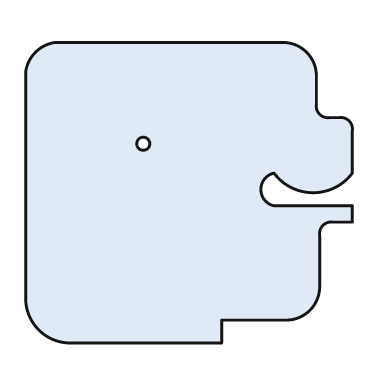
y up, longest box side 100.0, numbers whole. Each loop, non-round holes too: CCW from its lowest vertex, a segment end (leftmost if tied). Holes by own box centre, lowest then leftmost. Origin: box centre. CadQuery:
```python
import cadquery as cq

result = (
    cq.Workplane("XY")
    .moveTo(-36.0, -46.0)
    .lineTo(10.0, -46.0)
    .lineTo(10.0, -39.0)
    .lineTo(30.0, -39.0)
    .threePointArc((37.0, -36.0), (40.0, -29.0))
    .lineTo(40.0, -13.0)
    .threePointArc((41.0, -10.0), (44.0, -9.0))
    .lineTo(50.0, -9.0)
    .lineTo(50.0, -4.0)
    .lineTo(26.0, -4.0)
    .threePointArc((22.0, 1.0), (26.0, 6.0))
    .threePointArc((38.0, 0.0), (50.0, 6.0))
    .lineTo(50.0, 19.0)
    .threePointArc((49.0, 22.0), (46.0, 23.0))
    .lineTo(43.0, 23.0)
    .threePointArc((40.0, 24.0), (39.0, 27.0))
    .lineTo(39.0, 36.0)
    .threePointArc((36.0, 43.0), (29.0, 46.0))
    .lineTo(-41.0, 46.0)
    .threePointArc((-47.0, 43.0), (-50.0, 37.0))
    .lineTo(-50.0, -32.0)
    .threePointArc((-46.0, -42.0), (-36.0, -46.0))
    .close()
    .moveTo(-14.0, 15.0)
    .circle(2.0)
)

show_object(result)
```